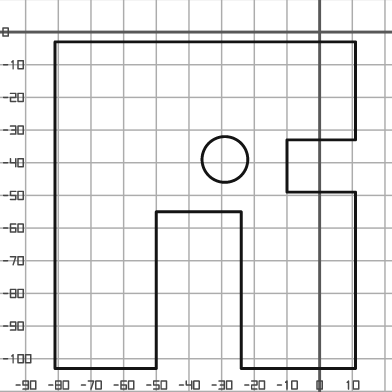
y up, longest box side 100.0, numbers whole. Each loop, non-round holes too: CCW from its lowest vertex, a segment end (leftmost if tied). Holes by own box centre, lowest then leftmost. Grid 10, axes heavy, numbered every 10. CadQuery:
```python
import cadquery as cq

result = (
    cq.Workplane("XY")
    .moveTo(-81.0, -103.0)
    .lineTo(-50.0, -103.0)
    .lineTo(-50.0, -55.0)
    .lineTo(-24.0, -55.0)
    .lineTo(-24.0, -103.0)
    .lineTo(11.0, -103.0)
    .lineTo(11.0, -49.0)
    .lineTo(-10.0, -49.0)
    .lineTo(-10.0, -33.0)
    .lineTo(11.0, -33.0)
    .lineTo(11.0, -3.0)
    .lineTo(-81.0, -3.0)
    .close()
    .moveTo(-29.0, -39.0)
    .circle(7.0)
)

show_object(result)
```